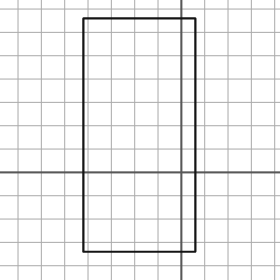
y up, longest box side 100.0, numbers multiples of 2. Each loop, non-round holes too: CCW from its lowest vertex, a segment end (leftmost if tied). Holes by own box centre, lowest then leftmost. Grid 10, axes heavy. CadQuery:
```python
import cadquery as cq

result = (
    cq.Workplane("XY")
    .moveTo(-42.0, -34.0)
    .lineTo(6.0, -34.0)
    .lineTo(6.0, 66.0)
    .lineTo(-42.0, 66.0)
    .close()
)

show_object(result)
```